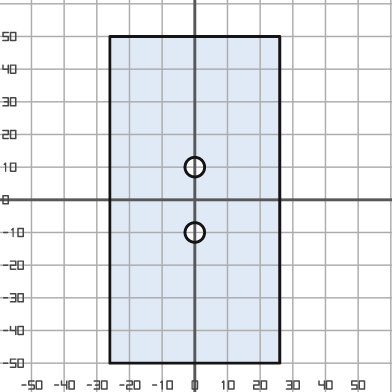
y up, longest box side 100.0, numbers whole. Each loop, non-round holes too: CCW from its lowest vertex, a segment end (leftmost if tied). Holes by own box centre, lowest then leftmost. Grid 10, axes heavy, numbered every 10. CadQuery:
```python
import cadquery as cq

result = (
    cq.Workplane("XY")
    .moveTo(-26.0, -50.0)
    .lineTo(26.0, -50.0)
    .lineTo(26.0, 50.0)
    .lineTo(-26.0, 50.0)
    .close()
    .moveTo(0.0, -10.0)
    .circle(3.0)
    .moveTo(0.0, 10.0)
    .circle(3.0)
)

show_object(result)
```